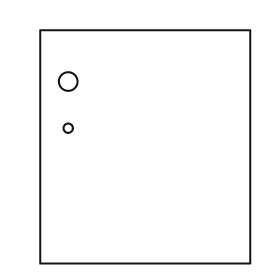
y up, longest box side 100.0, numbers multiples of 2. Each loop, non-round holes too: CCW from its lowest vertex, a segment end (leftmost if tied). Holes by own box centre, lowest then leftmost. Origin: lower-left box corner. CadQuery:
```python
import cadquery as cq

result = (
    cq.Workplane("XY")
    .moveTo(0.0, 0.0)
    .lineTo(90.0, 0.0)
    .lineTo(90.0, 100.0)
    .lineTo(0.0, 100.0)
    .close()
    .moveTo(12.0, 58.0)
    .circle(2.0)
    .moveTo(12.0, 78.0)
    .circle(4.0)
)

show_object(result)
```